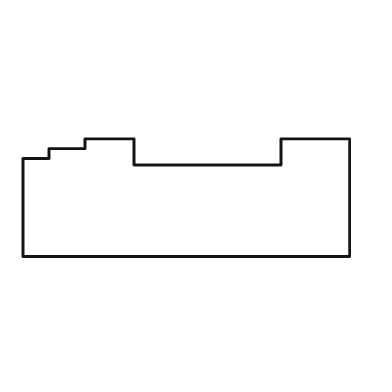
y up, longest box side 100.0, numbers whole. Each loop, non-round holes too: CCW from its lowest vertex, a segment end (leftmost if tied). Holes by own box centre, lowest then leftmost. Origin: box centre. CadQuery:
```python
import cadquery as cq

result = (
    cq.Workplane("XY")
    .moveTo(-50.0, -18.0)
    .lineTo(50.0, -18.0)
    .lineTo(50.0, 18.0)
    .lineTo(29.0, 18.0)
    .lineTo(29.0, 10.0)
    .lineTo(-16.0, 10.0)
    .lineTo(-16.0, 18.0)
    .lineTo(-31.0, 18.0)
    .lineTo(-31.0, 15.0)
    .lineTo(-42.0, 15.0)
    .lineTo(-42.0, 12.0)
    .lineTo(-50.0, 12.0)
    .close()
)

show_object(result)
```